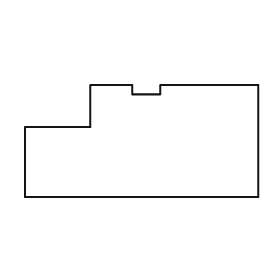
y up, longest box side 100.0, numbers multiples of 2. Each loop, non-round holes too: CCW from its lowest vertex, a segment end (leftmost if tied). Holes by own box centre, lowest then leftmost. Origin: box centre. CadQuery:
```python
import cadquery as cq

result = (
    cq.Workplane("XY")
    .moveTo(-50.0, -24.0)
    .lineTo(50.0, -24.0)
    .lineTo(50.0, 24.0)
    .lineTo(8.0, 24.0)
    .lineTo(8.0, 20.0)
    .lineTo(-4.0, 20.0)
    .lineTo(-4.0, 24.0)
    .lineTo(-22.0, 24.0)
    .lineTo(-22.0, 6.0)
    .lineTo(-50.0, 6.0)
    .close()
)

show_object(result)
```